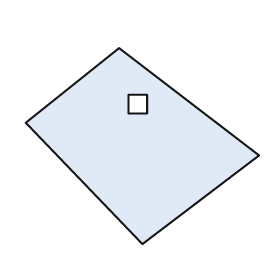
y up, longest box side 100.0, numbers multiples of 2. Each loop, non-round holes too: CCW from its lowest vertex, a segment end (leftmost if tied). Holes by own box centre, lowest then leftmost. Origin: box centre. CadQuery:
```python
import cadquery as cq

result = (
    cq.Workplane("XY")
    .moveTo(0.0, -42.0)
    .lineTo(50.0, -4.0)
    .lineTo(-10.0, 42.0)
    .lineTo(-50.0, 10.0)
    .close()
    .moveTo(-6.0, 14.0)
    .lineTo(2.0, 14.0)
    .lineTo(2.0, 22.0)
    .lineTo(-6.0, 22.0)
    .close()
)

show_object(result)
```